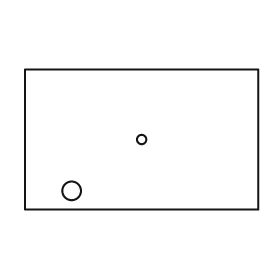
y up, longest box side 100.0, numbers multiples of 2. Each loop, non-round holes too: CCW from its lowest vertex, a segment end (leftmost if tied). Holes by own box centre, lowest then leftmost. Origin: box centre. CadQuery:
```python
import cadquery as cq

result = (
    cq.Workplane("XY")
    .moveTo(-50.0, -30.0)
    .lineTo(50.0, -30.0)
    .lineTo(50.0, 30.0)
    .lineTo(-50.0, 30.0)
    .close()
    .moveTo(-30.0, -22.0)
    .circle(4.0)
    .moveTo(0.0, 0.0)
    .circle(2.0)
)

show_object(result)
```